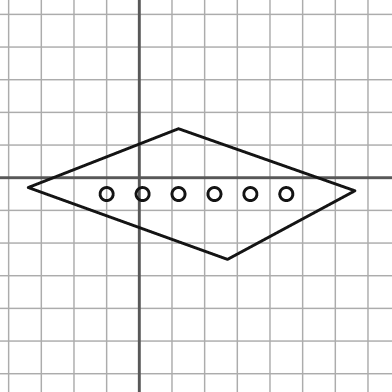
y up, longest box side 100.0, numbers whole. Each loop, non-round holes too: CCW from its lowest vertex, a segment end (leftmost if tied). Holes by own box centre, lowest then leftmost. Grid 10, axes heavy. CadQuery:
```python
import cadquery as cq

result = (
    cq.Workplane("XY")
    .moveTo(27.0, -25.0)
    .lineTo(66.0, -4.0)
    .lineTo(12.0, 15.0)
    .lineTo(-34.0, -3.0)
    .close()
    .moveTo(-10.0, -5.0)
    .circle(2.0)
    .moveTo(1.0, -5.0)
    .circle(2.0)
    .moveTo(12.0, -5.0)
    .circle(2.0)
    .moveTo(23.0, -5.0)
    .circle(2.0)
    .moveTo(34.0, -5.0)
    .circle(2.0)
    .moveTo(45.0, -5.0)
    .circle(2.0)
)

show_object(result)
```